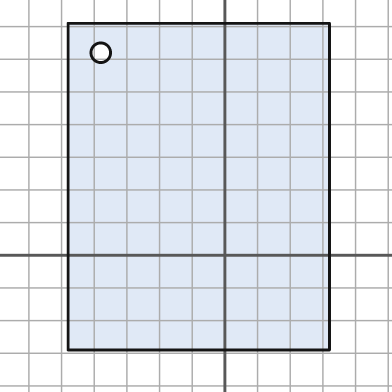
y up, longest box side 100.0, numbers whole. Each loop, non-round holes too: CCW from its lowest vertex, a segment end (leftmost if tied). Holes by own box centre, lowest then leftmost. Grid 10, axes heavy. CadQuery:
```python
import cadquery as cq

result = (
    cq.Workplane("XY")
    .moveTo(-48.0, -29.0)
    .lineTo(32.0, -29.0)
    .lineTo(32.0, 71.0)
    .lineTo(-48.0, 71.0)
    .close()
    .moveTo(-38.0, 62.0)
    .circle(3.0)
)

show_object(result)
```